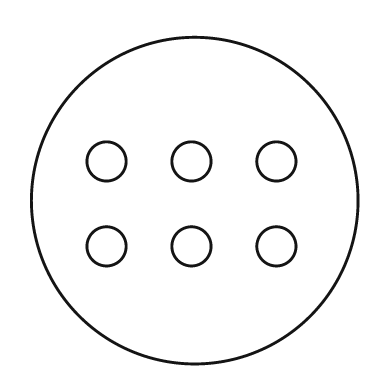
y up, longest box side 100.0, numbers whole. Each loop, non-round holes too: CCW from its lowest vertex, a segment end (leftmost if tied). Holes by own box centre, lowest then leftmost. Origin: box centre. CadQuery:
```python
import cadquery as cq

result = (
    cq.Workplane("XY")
    .moveTo(0.0, 0.0)
    .circle(50.0)
    .moveTo(-27.0, -14.0)
    .circle(6.0)
    .moveTo(-1.0, -14.0)
    .circle(6.0)
    .moveTo(25.0, -14.0)
    .circle(6.0)
    .moveTo(-27.0, 12.0)
    .circle(6.0)
    .moveTo(-1.0, 12.0)
    .circle(6.0)
    .moveTo(25.0, 12.0)
    .circle(6.0)
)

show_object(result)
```